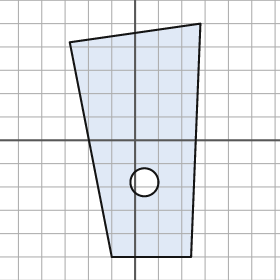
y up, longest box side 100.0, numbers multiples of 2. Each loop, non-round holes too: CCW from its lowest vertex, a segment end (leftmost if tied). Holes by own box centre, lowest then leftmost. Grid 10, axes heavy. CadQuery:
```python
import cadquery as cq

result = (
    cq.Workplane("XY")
    .moveTo(-10.0, -50.0)
    .lineTo(24.0, -50.0)
    .lineTo(28.0, 50.0)
    .lineTo(-28.0, 42.0)
    .close()
    .moveTo(4.0, -18.0)
    .circle(6.0)
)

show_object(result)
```